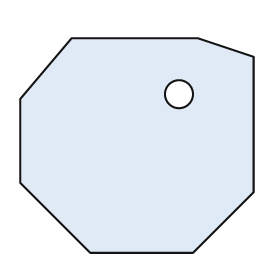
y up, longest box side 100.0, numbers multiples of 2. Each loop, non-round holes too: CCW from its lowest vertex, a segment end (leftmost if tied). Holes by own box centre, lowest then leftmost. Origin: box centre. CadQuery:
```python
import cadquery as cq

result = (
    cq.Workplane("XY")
    .moveTo(-20.0, -46.0)
    .lineTo(24.0, -46.0)
    .lineTo(50.0, -20.0)
    .lineTo(50.0, 38.0)
    .lineTo(26.0, 46.0)
    .lineTo(-28.0, 46.0)
    .lineTo(-50.0, 20.0)
    .lineTo(-50.0, -16.0)
    .close()
    .moveTo(18.0, 22.0)
    .circle(6.0)
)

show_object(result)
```